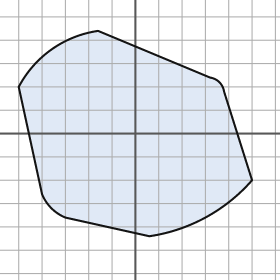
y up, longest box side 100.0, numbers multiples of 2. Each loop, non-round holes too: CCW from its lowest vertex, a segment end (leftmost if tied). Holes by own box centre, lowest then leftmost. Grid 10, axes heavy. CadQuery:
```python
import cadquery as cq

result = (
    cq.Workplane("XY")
    .moveTo(6.0, -44.0)
    .threePointArc((30.0, -36.0), (50.0, -20.0))
    .lineTo(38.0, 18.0)
    .threePointArc((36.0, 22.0), (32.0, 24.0))
    .lineTo(-16.0, 44.0)
    .threePointArc((-36.0, 36.0), (-50.0, 20.0))
    .lineTo(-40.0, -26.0)
    .threePointArc((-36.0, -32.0), (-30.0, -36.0))
    .close()
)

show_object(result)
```